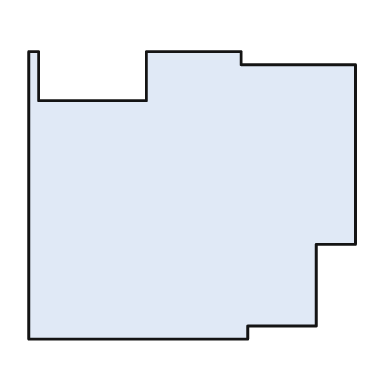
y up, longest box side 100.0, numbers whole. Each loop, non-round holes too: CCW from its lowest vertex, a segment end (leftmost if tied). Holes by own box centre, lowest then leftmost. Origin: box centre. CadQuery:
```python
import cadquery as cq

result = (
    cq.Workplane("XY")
    .moveTo(-50.0, -44.0)
    .lineTo(17.0, -44.0)
    .lineTo(17.0, -40.0)
    .lineTo(38.0, -40.0)
    .lineTo(38.0, -15.0)
    .lineTo(50.0, -15.0)
    .lineTo(50.0, 40.0)
    .lineTo(15.0, 40.0)
    .lineTo(15.0, 44.0)
    .lineTo(-14.0, 44.0)
    .lineTo(-14.0, 29.0)
    .lineTo(-47.0, 29.0)
    .lineTo(-47.0, 44.0)
    .lineTo(-50.0, 44.0)
    .close()
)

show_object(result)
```